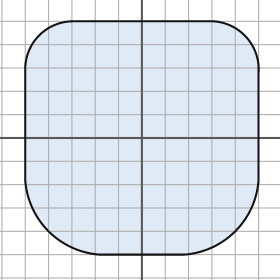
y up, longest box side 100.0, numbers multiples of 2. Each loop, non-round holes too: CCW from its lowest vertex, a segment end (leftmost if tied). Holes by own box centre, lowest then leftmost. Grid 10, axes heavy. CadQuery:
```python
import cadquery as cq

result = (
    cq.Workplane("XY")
    .moveTo(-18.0, -50.0)
    .lineTo(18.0, -50.0)
    .threePointArc((40.0, -40.0), (50.0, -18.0))
    .lineTo(50.0, 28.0)
    .threePointArc((44.0, 44.0), (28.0, 50.0))
    .lineTo(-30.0, 50.0)
    .threePointArc((-44.0, 44.0), (-50.0, 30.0))
    .lineTo(-50.0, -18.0)
    .threePointArc((-40.0, -40.0), (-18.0, -50.0))
    .close()
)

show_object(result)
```